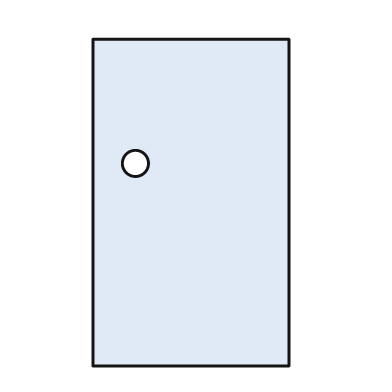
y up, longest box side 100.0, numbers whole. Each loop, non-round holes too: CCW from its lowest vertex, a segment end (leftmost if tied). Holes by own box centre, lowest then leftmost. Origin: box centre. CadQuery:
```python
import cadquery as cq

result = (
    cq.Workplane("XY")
    .moveTo(-30.0, -50.0)
    .lineTo(30.0, -50.0)
    .lineTo(30.0, 50.0)
    .lineTo(-30.0, 50.0)
    .close()
    .moveTo(-17.0, 12.0)
    .circle(4.0)
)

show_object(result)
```